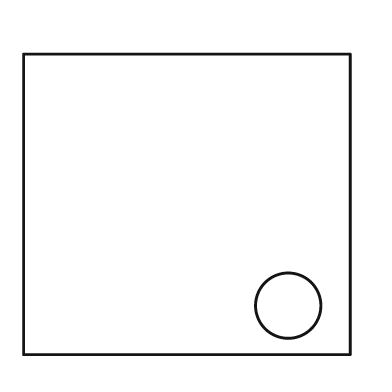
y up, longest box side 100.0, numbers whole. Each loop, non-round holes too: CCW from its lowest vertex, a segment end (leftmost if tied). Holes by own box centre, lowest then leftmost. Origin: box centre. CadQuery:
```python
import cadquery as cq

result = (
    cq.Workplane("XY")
    .moveTo(-50.0, -46.0)
    .lineTo(50.0, -46.0)
    .lineTo(50.0, 46.0)
    .lineTo(-50.0, 46.0)
    .close()
    .moveTo(31.0, -31.0)
    .circle(10.0)
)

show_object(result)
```